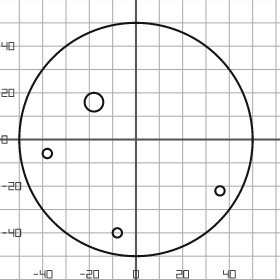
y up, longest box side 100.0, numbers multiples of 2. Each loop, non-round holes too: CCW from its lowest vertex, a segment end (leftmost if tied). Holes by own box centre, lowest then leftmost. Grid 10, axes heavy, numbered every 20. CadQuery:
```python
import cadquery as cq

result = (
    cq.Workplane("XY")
    .moveTo(0.0, 0.0)
    .circle(50.0)
    .moveTo(-8.0, -40.0)
    .circle(2.0)
    .moveTo(36.0, -22.0)
    .circle(2.0)
    .moveTo(-38.0, -6.0)
    .circle(2.0)
    .moveTo(-18.0, 16.0)
    .circle(4.0)
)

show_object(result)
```